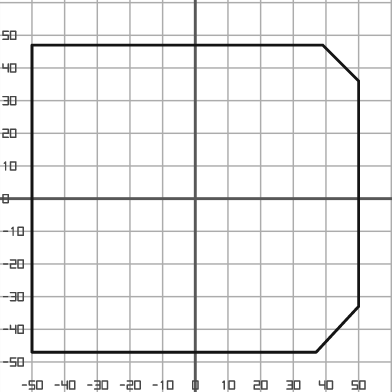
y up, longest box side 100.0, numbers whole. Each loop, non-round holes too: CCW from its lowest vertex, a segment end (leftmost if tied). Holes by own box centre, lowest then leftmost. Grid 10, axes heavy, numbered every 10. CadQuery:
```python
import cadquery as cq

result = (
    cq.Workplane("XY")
    .moveTo(-50.0, -47.0)
    .lineTo(37.0, -47.0)
    .lineTo(50.0, -33.0)
    .lineTo(50.0, 36.0)
    .lineTo(39.0, 47.0)
    .lineTo(-50.0, 47.0)
    .close()
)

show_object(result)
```